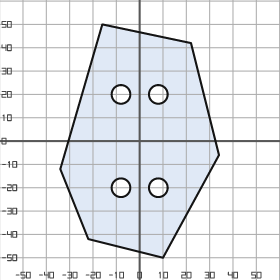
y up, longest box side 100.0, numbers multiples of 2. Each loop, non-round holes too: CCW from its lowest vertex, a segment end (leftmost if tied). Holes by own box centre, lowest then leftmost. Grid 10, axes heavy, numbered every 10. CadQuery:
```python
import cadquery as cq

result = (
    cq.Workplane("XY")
    .moveTo(10.0, -50.0)
    .lineTo(34.0, -6.0)
    .lineTo(22.0, 42.0)
    .lineTo(-16.0, 50.0)
    .lineTo(-34.0, -12.0)
    .lineTo(-22.0, -42.0)
    .close()
    .moveTo(-8.0, -20.0)
    .circle(4.0)
    .moveTo(8.0, -20.0)
    .circle(4.0)
    .moveTo(-8.0, 20.0)
    .circle(4.0)
    .moveTo(8.0, 20.0)
    .circle(4.0)
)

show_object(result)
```